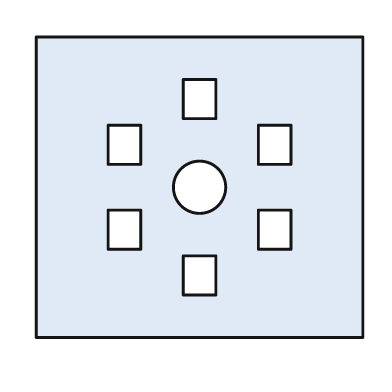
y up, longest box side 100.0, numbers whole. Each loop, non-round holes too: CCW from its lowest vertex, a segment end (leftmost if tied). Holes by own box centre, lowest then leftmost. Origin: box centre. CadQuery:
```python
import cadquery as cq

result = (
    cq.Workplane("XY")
    .moveTo(-50.0, -46.0)
    .lineTo(50.0, -46.0)
    .lineTo(50.0, 46.0)
    .lineTo(-50.0, 46.0)
    .close()
    .moveTo(-5.0, -33.0)
    .lineTo(5.0, -33.0)
    .lineTo(5.0, -21.0)
    .lineTo(-5.0, -21.0)
    .close()
    .moveTo(-28.0, -19.0)
    .lineTo(-18.0, -19.0)
    .lineTo(-18.0, -7.0)
    .lineTo(-28.0, -7.0)
    .close()
    .moveTo(18.0, -19.0)
    .lineTo(28.0, -19.0)
    .lineTo(28.0, -7.0)
    .lineTo(18.0, -7.0)
    .close()
    .moveTo(0.0, 0.0)
    .circle(8.0)
    .moveTo(-28.0, 7.0)
    .lineTo(-18.0, 7.0)
    .lineTo(-18.0, 19.0)
    .lineTo(-28.0, 19.0)
    .close()
    .moveTo(18.0, 7.0)
    .lineTo(28.0, 7.0)
    .lineTo(28.0, 19.0)
    .lineTo(18.0, 19.0)
    .close()
    .moveTo(-5.0, 21.0)
    .lineTo(5.0, 21.0)
    .lineTo(5.0, 33.0)
    .lineTo(-5.0, 33.0)
    .close()
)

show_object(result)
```